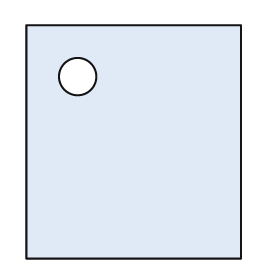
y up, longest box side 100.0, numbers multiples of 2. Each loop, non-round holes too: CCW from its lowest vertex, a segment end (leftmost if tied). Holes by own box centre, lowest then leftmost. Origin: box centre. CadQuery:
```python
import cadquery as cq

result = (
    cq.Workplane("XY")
    .moveTo(-46.0, -50.0)
    .lineTo(46.0, -50.0)
    .lineTo(46.0, 50.0)
    .lineTo(-46.0, 50.0)
    .close()
    .moveTo(-24.0, 28.0)
    .circle(8.0)
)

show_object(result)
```